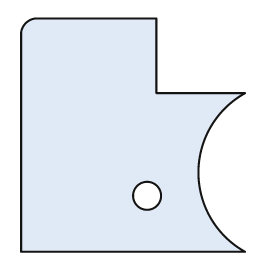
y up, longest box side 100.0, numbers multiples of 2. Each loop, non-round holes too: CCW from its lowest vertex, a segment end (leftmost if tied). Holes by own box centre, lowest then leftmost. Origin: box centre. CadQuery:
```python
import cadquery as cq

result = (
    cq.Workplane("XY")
    .moveTo(-48.0, -50.0)
    .lineTo(48.0, -50.0)
    .threePointArc((28.0, -16.0), (48.0, 18.0))
    .lineTo(10.0, 18.0)
    .lineTo(10.0, 50.0)
    .lineTo(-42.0, 50.0)
    .threePointArc((-46.0, 48.0), (-48.0, 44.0))
    .close()
    .moveTo(6.0, -26.0)
    .circle(6.0)
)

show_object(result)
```